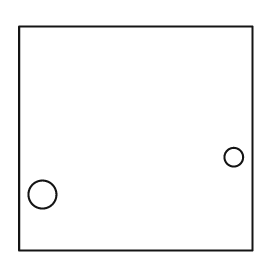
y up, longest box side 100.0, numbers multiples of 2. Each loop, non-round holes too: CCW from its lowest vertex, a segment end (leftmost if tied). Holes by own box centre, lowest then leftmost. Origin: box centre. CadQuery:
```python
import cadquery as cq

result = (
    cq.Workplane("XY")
    .moveTo(-50.0, -48.0)
    .lineTo(50.0, -48.0)
    .lineTo(50.0, 48.0)
    .lineTo(-50.0, 48.0)
    .close()
    .moveTo(-40.0, -24.0)
    .circle(6.0)
    .moveTo(42.0, -8.0)
    .circle(4.0)
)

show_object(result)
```